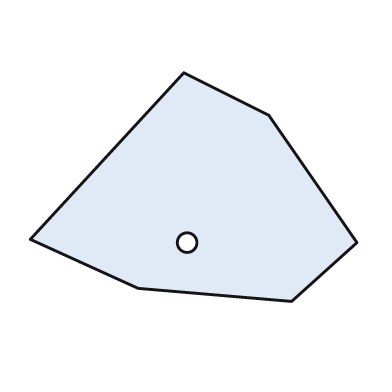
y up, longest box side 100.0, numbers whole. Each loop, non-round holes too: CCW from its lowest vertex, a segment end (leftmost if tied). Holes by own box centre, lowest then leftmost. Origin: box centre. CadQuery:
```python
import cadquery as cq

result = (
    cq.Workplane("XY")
    .moveTo(30.0, -35.0)
    .lineTo(50.0, -17.0)
    .lineTo(23.0, 22.0)
    .lineTo(-3.0, 35.0)
    .lineTo(-50.0, -16.0)
    .lineTo(-17.0, -31.0)
    .close()
    .moveTo(-2.0, -17.0)
    .circle(3.0)
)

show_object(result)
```